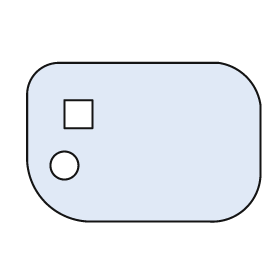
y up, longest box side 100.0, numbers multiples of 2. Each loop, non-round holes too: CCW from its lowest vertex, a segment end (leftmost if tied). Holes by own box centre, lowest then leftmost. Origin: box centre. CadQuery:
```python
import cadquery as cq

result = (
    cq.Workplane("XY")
    .moveTo(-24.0, -34.0)
    .lineTo(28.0, -34.0)
    .threePointArc((44.0, -28.0), (50.0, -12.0))
    .lineTo(50.0, 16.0)
    .threePointArc((44.0, 28.0), (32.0, 34.0))
    .lineTo(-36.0, 34.0)
    .threePointArc((-46.0, 30.0), (-50.0, 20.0))
    .lineTo(-50.0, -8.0)
    .threePointArc((-42.0, -26.0), (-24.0, -34.0))
    .close()
    .moveTo(-34.0, -10.0)
    .circle(6.0)
    .moveTo(-34.0, 6.0)
    .lineTo(-22.0, 6.0)
    .lineTo(-22.0, 18.0)
    .lineTo(-34.0, 18.0)
    .close()
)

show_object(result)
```